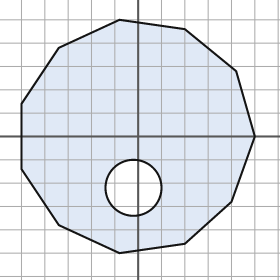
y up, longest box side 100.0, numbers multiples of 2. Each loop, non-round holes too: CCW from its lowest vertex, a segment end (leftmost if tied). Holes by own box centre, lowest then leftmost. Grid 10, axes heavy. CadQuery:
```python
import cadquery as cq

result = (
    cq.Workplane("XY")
    .moveTo(-8.0, -50.0)
    .lineTo(20.0, -46.0)
    .lineTo(40.0, -28.0)
    .lineTo(50.0, 0.0)
    .lineTo(42.0, 28.0)
    .lineTo(20.0, 46.0)
    .lineTo(-8.0, 50.0)
    .lineTo(-34.0, 38.0)
    .lineTo(-50.0, 14.0)
    .lineTo(-50.0, -14.0)
    .lineTo(-34.0, -38.0)
    .close()
    .moveTo(-2.0, -22.0)
    .circle(12.0)
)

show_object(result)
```